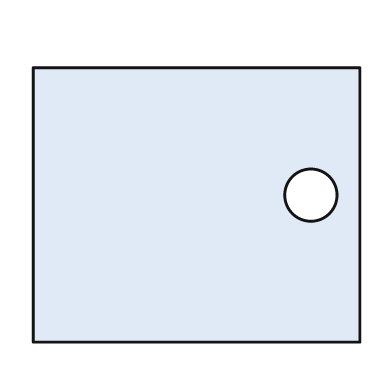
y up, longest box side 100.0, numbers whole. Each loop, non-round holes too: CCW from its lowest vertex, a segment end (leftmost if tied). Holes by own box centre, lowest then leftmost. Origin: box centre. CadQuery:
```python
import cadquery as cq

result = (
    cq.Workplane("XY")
    .moveTo(-50.0, -42.0)
    .lineTo(50.0, -42.0)
    .lineTo(50.0, 42.0)
    .lineTo(-50.0, 42.0)
    .close()
    .moveTo(35.0, 3.0)
    .circle(8.0)
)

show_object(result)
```